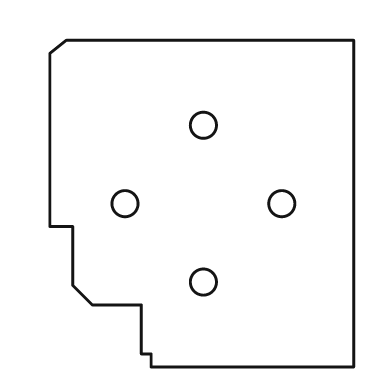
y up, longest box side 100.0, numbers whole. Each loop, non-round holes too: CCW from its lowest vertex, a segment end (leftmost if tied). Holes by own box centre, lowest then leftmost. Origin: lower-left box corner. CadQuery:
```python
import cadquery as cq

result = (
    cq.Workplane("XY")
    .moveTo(31.0, 0.0)
    .lineTo(93.0, 0.0)
    .lineTo(93.0, 100.0)
    .lineTo(5.0, 100.0)
    .lineTo(0.0, 96.0)
    .lineTo(0.0, 43.0)
    .lineTo(7.0, 43.0)
    .lineTo(7.0, 25.0)
    .lineTo(13.0, 19.0)
    .lineTo(28.0, 19.0)
    .lineTo(28.0, 4.0)
    .lineTo(31.0, 4.0)
    .close()
    .moveTo(47.0, 26.0)
    .circle(4.0)
    .moveTo(23.0, 50.0)
    .circle(4.0)
    .moveTo(71.0, 50.0)
    .circle(4.0)
    .moveTo(47.0, 74.0)
    .circle(4.0)
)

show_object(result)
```